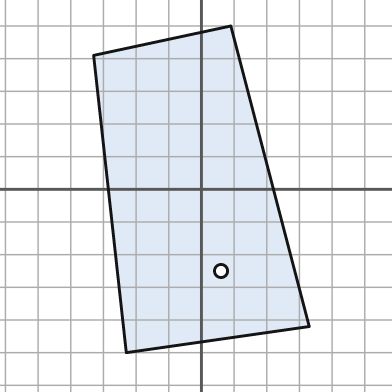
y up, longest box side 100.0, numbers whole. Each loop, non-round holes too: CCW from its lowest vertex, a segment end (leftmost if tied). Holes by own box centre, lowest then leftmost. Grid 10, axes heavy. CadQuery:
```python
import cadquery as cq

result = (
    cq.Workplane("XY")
    .moveTo(-23.0, -50.0)
    .lineTo(33.0, -42.0)
    .lineTo(9.0, 50.0)
    .lineTo(-33.0, 41.0)
    .close()
    .moveTo(6.0, -25.0)
    .circle(2.0)
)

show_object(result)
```